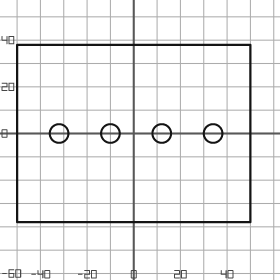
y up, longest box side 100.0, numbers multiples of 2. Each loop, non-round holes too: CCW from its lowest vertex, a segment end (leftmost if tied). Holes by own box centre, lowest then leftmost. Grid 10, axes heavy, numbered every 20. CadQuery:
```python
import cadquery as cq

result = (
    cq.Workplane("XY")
    .moveTo(-50.0, -38.0)
    .lineTo(50.0, -38.0)
    .lineTo(50.0, 38.0)
    .lineTo(-50.0, 38.0)
    .close()
    .moveTo(-32.0, 0.0)
    .circle(4.0)
    .moveTo(-10.0, 0.0)
    .circle(4.0)
    .moveTo(12.0, 0.0)
    .circle(4.0)
    .moveTo(34.0, 0.0)
    .circle(4.0)
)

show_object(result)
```